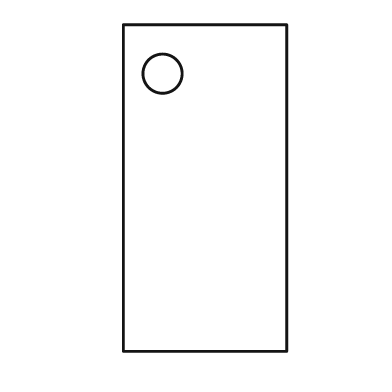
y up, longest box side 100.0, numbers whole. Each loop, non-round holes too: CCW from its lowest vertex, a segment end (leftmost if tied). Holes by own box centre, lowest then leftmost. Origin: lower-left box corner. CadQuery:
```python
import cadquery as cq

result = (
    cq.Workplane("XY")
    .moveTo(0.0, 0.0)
    .lineTo(50.0, 0.0)
    .lineTo(50.0, 100.0)
    .lineTo(0.0, 100.0)
    .close()
    .moveTo(12.0, 85.0)
    .circle(6.0)
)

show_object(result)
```